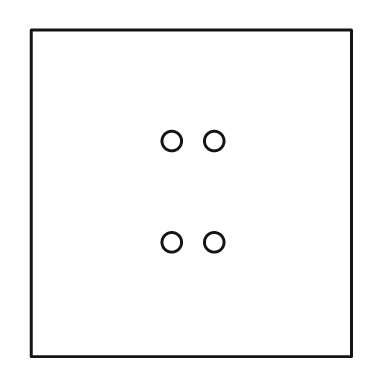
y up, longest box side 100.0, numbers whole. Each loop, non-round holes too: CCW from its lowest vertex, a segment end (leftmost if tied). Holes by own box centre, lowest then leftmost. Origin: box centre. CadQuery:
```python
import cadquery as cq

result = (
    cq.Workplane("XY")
    .moveTo(-49.0, -50.0)
    .lineTo(49.0, -50.0)
    .lineTo(49.0, 50.0)
    .lineTo(-49.0, 50.0)
    .close()
    .moveTo(-6.0, -15.0)
    .circle(3.0)
    .moveTo(7.0, -15.0)
    .circle(3.0)
    .moveTo(-6.0, 16.0)
    .circle(3.0)
    .moveTo(7.0, 16.0)
    .circle(3.0)
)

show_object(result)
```